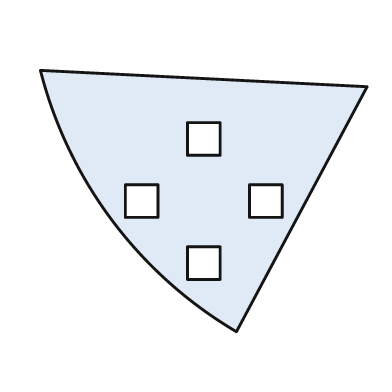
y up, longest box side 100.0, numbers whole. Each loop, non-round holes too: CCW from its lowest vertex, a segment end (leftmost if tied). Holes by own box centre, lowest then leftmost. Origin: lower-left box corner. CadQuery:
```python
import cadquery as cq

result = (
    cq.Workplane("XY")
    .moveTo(60.0, 0.0)
    .lineTo(100.0, 75.0)
    .lineTo(0.0, 80.0)
    .threePointArc((22.0, 34.0), (60.0, 0.0))
    .close()
    .moveTo(45.0, 16.0)
    .lineTo(55.0, 16.0)
    .lineTo(55.0, 26.0)
    .lineTo(45.0, 26.0)
    .close()
    .moveTo(26.0, 35.0)
    .lineTo(36.0, 35.0)
    .lineTo(36.0, 45.0)
    .lineTo(26.0, 45.0)
    .close()
    .moveTo(64.0, 35.0)
    .lineTo(74.0, 35.0)
    .lineTo(74.0, 45.0)
    .lineTo(64.0, 45.0)
    .close()
    .moveTo(45.0, 54.0)
    .lineTo(55.0, 54.0)
    .lineTo(55.0, 64.0)
    .lineTo(45.0, 64.0)
    .close()
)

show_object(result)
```